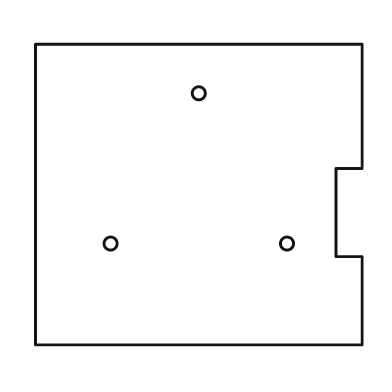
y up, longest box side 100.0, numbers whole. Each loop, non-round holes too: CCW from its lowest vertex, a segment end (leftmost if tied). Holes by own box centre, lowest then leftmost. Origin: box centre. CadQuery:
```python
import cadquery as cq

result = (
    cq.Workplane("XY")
    .moveTo(-50.0, -46.0)
    .lineTo(50.0, -46.0)
    .lineTo(50.0, -19.0)
    .lineTo(42.0, -19.0)
    .lineTo(42.0, 8.0)
    .lineTo(50.0, 8.0)
    .lineTo(50.0, 46.0)
    .lineTo(-50.0, 46.0)
    .close()
    .moveTo(-27.0, -15.0)
    .circle(2.0)
    .moveTo(27.0, -15.0)
    .circle(2.0)
    .moveTo(0.0, 31.0)
    .circle(2.0)
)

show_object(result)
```